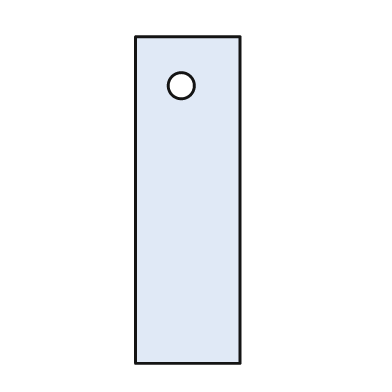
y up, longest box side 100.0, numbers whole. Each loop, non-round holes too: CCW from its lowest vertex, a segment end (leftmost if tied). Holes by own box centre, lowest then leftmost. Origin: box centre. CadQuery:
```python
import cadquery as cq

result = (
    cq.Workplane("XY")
    .moveTo(-16.0, -50.0)
    .lineTo(16.0, -50.0)
    .lineTo(16.0, 50.0)
    .lineTo(-16.0, 50.0)
    .close()
    .moveTo(-2.0, 35.0)
    .circle(4.0)
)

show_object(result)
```